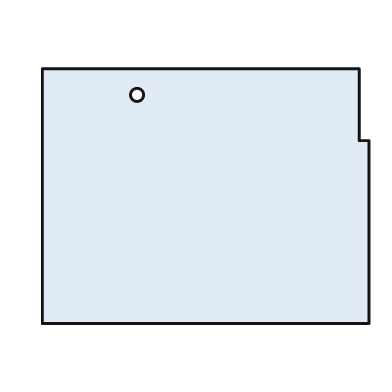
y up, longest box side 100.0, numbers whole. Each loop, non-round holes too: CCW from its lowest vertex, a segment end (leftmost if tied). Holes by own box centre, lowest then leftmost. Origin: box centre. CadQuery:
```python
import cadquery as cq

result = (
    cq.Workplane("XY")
    .moveTo(-50.0, -39.0)
    .lineTo(50.0, -39.0)
    .lineTo(50.0, 17.0)
    .lineTo(47.0, 17.0)
    .lineTo(47.0, 39.0)
    .lineTo(-50.0, 39.0)
    .close()
    .moveTo(-21.0, 31.0)
    .circle(2.0)
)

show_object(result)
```